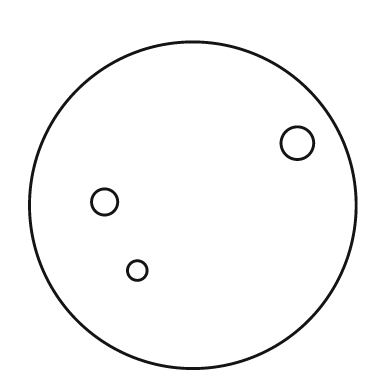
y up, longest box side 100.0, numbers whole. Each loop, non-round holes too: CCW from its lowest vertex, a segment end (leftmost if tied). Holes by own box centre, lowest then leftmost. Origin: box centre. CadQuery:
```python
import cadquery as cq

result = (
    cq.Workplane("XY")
    .moveTo(0.0, 0.0)
    .circle(50.0)
    .moveTo(-17.0, -20.0)
    .circle(3.0)
    .moveTo(-27.0, 1.0)
    .circle(4.0)
    .moveTo(32.0, 19.0)
    .circle(5.0)
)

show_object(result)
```